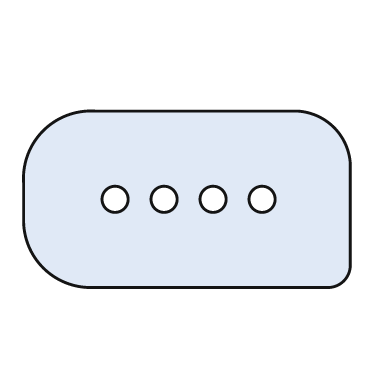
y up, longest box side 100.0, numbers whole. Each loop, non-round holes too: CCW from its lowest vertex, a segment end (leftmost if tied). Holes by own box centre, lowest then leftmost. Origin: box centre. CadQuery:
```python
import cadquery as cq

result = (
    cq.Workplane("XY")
    .moveTo(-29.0, -27.0)
    .lineTo(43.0, -27.0)
    .threePointArc((48.0, -25.0), (50.0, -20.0))
    .lineTo(50.0, 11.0)
    .threePointArc((45.0, 22.0), (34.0, 27.0))
    .lineTo(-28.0, 27.0)
    .threePointArc((-44.0, 21.0), (-50.0, 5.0))
    .lineTo(-50.0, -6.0)
    .threePointArc((-44.0, -21.0), (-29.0, -27.0))
    .close()
    .moveTo(-22.0, 0.0)
    .circle(4.0)
    .moveTo(-7.0, 0.0)
    .circle(4.0)
    .moveTo(8.0, 0.0)
    .circle(4.0)
    .moveTo(23.0, 0.0)
    .circle(4.0)
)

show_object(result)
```